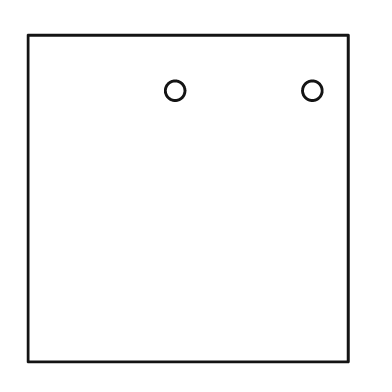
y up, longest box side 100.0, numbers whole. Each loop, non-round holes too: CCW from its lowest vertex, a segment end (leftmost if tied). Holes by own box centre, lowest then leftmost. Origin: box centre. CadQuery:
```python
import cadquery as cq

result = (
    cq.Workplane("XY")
    .moveTo(-49.0, -50.0)
    .lineTo(49.0, -50.0)
    .lineTo(49.0, 50.0)
    .lineTo(-49.0, 50.0)
    .close()
    .moveTo(-4.0, 33.0)
    .circle(3.0)
    .moveTo(38.0, 33.0)
    .circle(3.0)
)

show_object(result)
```